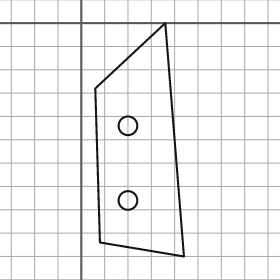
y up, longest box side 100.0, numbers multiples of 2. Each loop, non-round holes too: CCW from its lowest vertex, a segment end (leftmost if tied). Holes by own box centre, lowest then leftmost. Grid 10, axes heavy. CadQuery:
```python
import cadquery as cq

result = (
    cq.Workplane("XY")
    .moveTo(44.0, -100.0)
    .lineTo(36.0, 0.0)
    .lineTo(6.0, -28.0)
    .lineTo(8.0, -94.0)
    .close()
    .moveTo(20.0, -76.0)
    .circle(4.0)
    .moveTo(20.0, -44.0)
    .circle(4.0)
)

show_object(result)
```